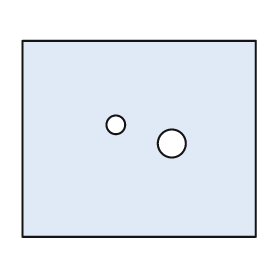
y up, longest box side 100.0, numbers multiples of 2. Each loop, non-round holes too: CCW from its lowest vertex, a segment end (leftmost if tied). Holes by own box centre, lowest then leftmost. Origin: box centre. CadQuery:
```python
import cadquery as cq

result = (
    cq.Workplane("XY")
    .moveTo(-50.0, -42.0)
    .lineTo(50.0, -42.0)
    .lineTo(50.0, 42.0)
    .lineTo(-50.0, 42.0)
    .close()
    .moveTo(14.0, -2.0)
    .circle(6.0)
    .moveTo(-10.0, 6.0)
    .circle(4.0)
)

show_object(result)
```